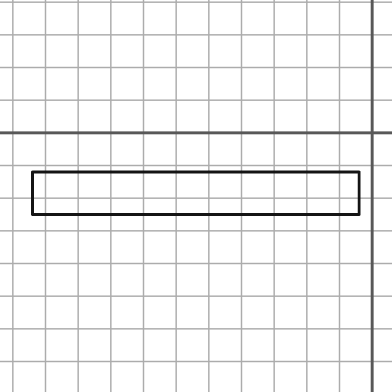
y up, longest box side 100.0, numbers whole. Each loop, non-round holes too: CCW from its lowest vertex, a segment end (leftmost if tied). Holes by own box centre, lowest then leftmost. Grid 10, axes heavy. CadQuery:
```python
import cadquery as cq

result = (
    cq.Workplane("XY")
    .moveTo(-104.0, -25.0)
    .lineTo(-4.0, -25.0)
    .lineTo(-4.0, -12.0)
    .lineTo(-104.0, -12.0)
    .close()
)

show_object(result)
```